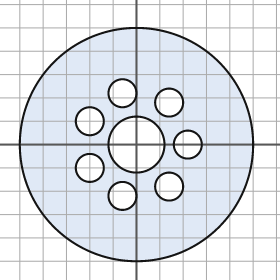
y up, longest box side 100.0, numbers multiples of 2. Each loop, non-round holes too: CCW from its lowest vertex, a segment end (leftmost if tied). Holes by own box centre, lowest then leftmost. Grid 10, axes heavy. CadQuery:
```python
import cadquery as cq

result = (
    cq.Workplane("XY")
    .moveTo(0.0, 0.0)
    .circle(50.0)
    .moveTo(-6.0, -22.0)
    .circle(6.0)
    .moveTo(14.0, -18.0)
    .circle(6.0)
    .moveTo(-20.0, -10.0)
    .circle(6.0)
    .moveTo(0.0, 0.0)
    .circle(12.0)
    .moveTo(22.0, 0.0)
    .circle(6.0)
    .moveTo(-20.0, 10.0)
    .circle(6.0)
    .moveTo(14.0, 18.0)
    .circle(6.0)
    .moveTo(-6.0, 22.0)
    .circle(6.0)
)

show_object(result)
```